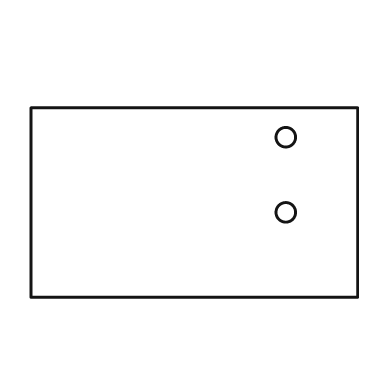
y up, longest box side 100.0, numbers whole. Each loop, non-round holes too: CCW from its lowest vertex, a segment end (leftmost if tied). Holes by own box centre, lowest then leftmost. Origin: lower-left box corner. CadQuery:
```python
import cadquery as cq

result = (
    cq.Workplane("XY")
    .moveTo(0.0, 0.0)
    .lineTo(100.0, 0.0)
    .lineTo(100.0, 58.0)
    .lineTo(0.0, 58.0)
    .close()
    .moveTo(78.0, 26.0)
    .circle(3.0)
    .moveTo(78.0, 49.0)
    .circle(3.0)
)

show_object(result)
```